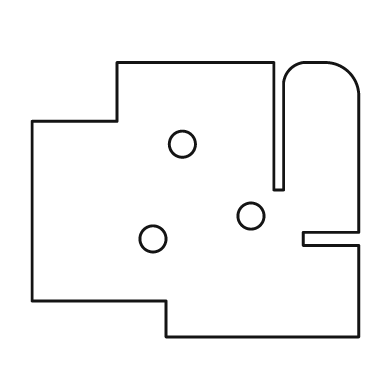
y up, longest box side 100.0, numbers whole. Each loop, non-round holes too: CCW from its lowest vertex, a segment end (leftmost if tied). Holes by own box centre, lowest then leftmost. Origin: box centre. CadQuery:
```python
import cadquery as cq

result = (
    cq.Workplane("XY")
    .moveTo(-9.0, -42.0)
    .lineTo(50.0, -42.0)
    .lineTo(50.0, -14.0)
    .lineTo(33.0, -14.0)
    .lineTo(33.0, -10.0)
    .lineTo(50.0, -10.0)
    .lineTo(50.0, 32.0)
    .threePointArc((47.0, 39.0), (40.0, 42.0))
    .lineTo(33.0, 42.0)
    .threePointArc((29.0, 40.0), (27.0, 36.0))
    .lineTo(27.0, 3.0)
    .lineTo(24.0, 3.0)
    .lineTo(24.0, 42.0)
    .lineTo(-24.0, 42.0)
    .lineTo(-24.0, 24.0)
    .lineTo(-50.0, 24.0)
    .lineTo(-50.0, -31.0)
    .lineTo(-9.0, -31.0)
    .close()
    .moveTo(-13.0, -12.0)
    .circle(4.0)
    .moveTo(17.0, -5.0)
    .circle(4.0)
    .moveTo(-4.0, 17.0)
    .circle(4.0)
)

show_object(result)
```